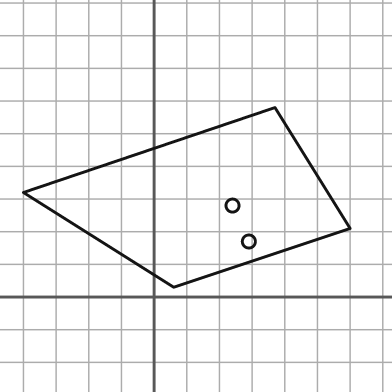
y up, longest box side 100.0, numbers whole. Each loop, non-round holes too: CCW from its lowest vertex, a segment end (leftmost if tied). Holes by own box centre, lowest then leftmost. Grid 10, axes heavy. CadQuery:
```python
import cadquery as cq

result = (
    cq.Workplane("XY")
    .moveTo(6.0, 3.0)
    .lineTo(60.0, 21.0)
    .lineTo(37.0, 58.0)
    .lineTo(-40.0, 32.0)
    .close()
    .moveTo(29.0, 17.0)
    .circle(2.0)
    .moveTo(24.0, 28.0)
    .circle(2.0)
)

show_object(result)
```